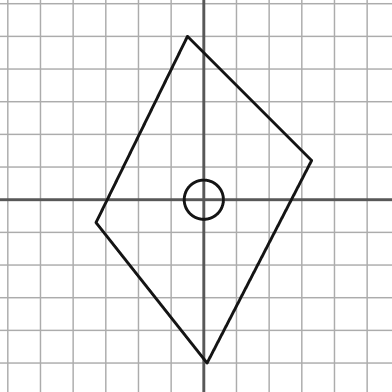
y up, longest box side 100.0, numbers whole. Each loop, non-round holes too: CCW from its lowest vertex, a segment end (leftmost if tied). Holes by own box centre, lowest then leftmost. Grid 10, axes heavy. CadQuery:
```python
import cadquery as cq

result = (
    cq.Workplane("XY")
    .moveTo(1.0, -50.0)
    .lineTo(33.0, 12.0)
    .lineTo(-5.0, 50.0)
    .lineTo(-33.0, -7.0)
    .close()
    .moveTo(0.0, 0.0)
    .circle(6.0)
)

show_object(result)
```